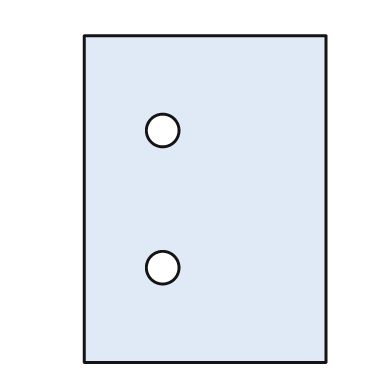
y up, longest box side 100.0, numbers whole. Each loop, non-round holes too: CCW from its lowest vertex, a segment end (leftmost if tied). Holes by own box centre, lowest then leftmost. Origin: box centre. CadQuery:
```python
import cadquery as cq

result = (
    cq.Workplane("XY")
    .moveTo(-37.0, -50.0)
    .lineTo(37.0, -50.0)
    .lineTo(37.0, 50.0)
    .lineTo(-37.0, 50.0)
    .close()
    .moveTo(-13.0, -21.0)
    .circle(5.0)
    .moveTo(-13.0, 21.0)
    .circle(5.0)
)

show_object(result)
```